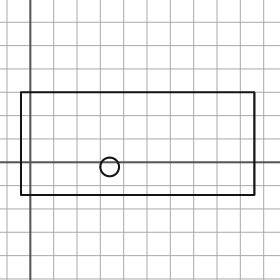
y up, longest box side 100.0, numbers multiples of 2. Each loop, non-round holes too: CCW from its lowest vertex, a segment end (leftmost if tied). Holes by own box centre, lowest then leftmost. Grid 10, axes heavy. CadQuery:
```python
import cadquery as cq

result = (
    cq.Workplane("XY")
    .moveTo(-4.0, -14.0)
    .lineTo(96.0, -14.0)
    .lineTo(96.0, 30.0)
    .lineTo(-4.0, 30.0)
    .close()
    .moveTo(34.0, -2.0)
    .circle(4.0)
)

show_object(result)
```